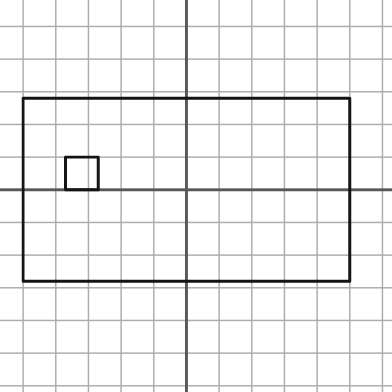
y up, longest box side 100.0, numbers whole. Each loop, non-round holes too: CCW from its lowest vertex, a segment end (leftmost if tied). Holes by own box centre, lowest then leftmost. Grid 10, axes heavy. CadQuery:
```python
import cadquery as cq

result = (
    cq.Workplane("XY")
    .moveTo(-50.0, -28.0)
    .lineTo(50.0, -28.0)
    .lineTo(50.0, 28.0)
    .lineTo(-50.0, 28.0)
    .close()
    .moveTo(-37.0, 0.0)
    .lineTo(-27.0, 0.0)
    .lineTo(-27.0, 10.0)
    .lineTo(-37.0, 10.0)
    .close()
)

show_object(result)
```